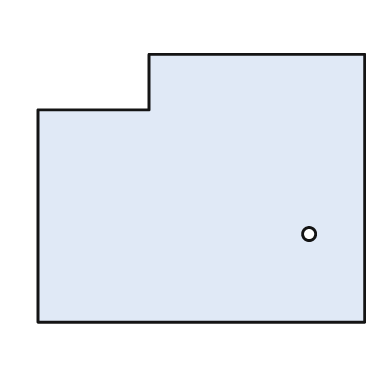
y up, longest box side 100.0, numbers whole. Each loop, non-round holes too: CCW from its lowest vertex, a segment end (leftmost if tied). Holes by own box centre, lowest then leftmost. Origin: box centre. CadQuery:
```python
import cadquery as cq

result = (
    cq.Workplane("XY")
    .moveTo(-50.0, -41.0)
    .lineTo(50.0, -41.0)
    .lineTo(50.0, 41.0)
    .lineTo(-16.0, 41.0)
    .lineTo(-16.0, 24.0)
    .lineTo(-50.0, 24.0)
    .close()
    .moveTo(33.0, -14.0)
    .circle(2.0)
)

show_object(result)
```